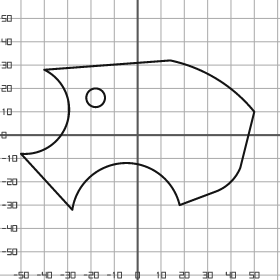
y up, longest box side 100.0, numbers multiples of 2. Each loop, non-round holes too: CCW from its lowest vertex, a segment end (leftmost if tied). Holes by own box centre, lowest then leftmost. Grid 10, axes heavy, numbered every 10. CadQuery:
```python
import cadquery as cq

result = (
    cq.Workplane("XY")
    .moveTo(-28.0, -32.0)
    .threePointArc((-6.0, -12.0), (18.0, -30.0))
    .lineTo(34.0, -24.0)
    .threePointArc((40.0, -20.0), (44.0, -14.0))
    .lineTo(50.0, 10.0)
    .threePointArc((34.0, 24.0), (14.0, 32.0))
    .lineTo(-40.0, 28.0)
    .threePointArc((-30.0, 6.0), (-50.0, -8.0))
    .close()
    .moveTo(-18.0, 16.0)
    .circle(4.0)
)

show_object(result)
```